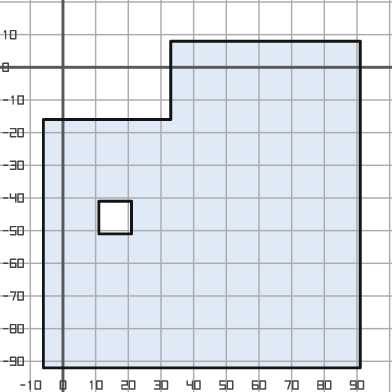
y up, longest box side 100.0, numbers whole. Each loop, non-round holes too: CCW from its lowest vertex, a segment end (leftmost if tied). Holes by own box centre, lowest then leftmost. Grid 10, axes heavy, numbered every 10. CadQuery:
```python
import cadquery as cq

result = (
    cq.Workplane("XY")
    .moveTo(-6.0, -92.0)
    .lineTo(91.0, -92.0)
    .lineTo(91.0, 8.0)
    .lineTo(33.0, 8.0)
    .lineTo(33.0, -16.0)
    .lineTo(-6.0, -16.0)
    .close()
    .moveTo(11.0, -51.0)
    .lineTo(21.0, -51.0)
    .lineTo(21.0, -41.0)
    .lineTo(11.0, -41.0)
    .close()
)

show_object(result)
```